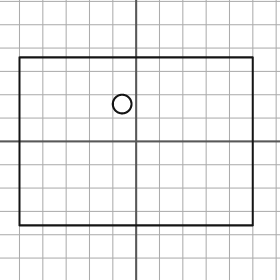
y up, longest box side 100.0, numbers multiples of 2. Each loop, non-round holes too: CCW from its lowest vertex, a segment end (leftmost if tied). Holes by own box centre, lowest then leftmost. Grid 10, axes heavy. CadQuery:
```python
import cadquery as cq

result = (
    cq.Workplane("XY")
    .moveTo(-50.0, -36.0)
    .lineTo(50.0, -36.0)
    .lineTo(50.0, 36.0)
    .lineTo(-50.0, 36.0)
    .close()
    .moveTo(-6.0, 16.0)
    .circle(4.0)
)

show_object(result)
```